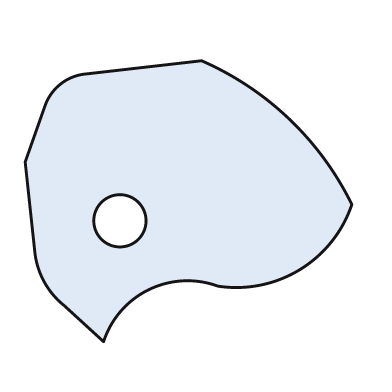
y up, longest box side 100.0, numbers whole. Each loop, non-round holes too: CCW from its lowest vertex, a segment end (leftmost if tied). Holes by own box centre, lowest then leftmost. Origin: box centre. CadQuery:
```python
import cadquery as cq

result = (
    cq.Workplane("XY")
    .moveTo(-26.0, -43.0)
    .threePointArc((-12.0, -27.0), (9.0, -26.0))
    .threePointArc((34.0, -21.0), (50.0, -1.0))
    .threePointArc((31.0, 25.0), (4.0, 43.0))
    .lineTo(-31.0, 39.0)
    .threePointArc((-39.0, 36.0), (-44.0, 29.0))
    .lineTo(-50.0, 12.0)
    .lineTo(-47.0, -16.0)
    .threePointArc((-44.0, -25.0), (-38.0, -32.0))
    .close()
    .moveTo(-21.0, -6.0)
    .circle(8.0)
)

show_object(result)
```